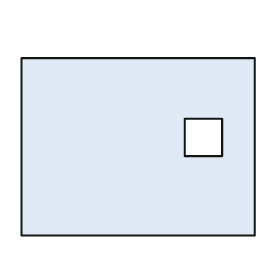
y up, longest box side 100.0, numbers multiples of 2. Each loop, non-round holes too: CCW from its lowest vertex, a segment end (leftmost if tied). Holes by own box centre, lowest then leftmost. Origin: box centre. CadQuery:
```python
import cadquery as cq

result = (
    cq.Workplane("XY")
    .moveTo(-50.0, -38.0)
    .lineTo(50.0, -38.0)
    .lineTo(50.0, 38.0)
    .lineTo(-50.0, 38.0)
    .close()
    .moveTo(20.0, -4.0)
    .lineTo(36.0, -4.0)
    .lineTo(36.0, 12.0)
    .lineTo(20.0, 12.0)
    .close()
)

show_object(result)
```